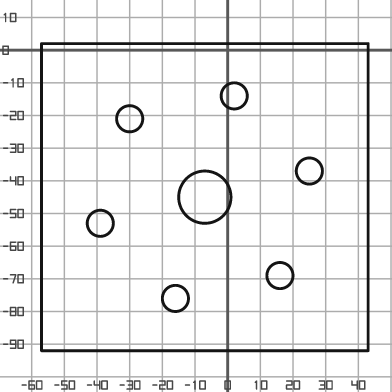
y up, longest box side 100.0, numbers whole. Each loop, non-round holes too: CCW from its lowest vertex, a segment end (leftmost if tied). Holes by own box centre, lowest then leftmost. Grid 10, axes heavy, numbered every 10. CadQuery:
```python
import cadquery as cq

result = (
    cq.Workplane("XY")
    .moveTo(-57.0, -92.0)
    .lineTo(43.0, -92.0)
    .lineTo(43.0, 2.0)
    .lineTo(-57.0, 2.0)
    .close()
    .moveTo(-16.0, -76.0)
    .circle(4.0)
    .moveTo(16.0, -69.0)
    .circle(4.0)
    .moveTo(-39.0, -53.0)
    .circle(4.0)
    .moveTo(-7.0, -45.0)
    .circle(8.0)
    .moveTo(25.0, -37.0)
    .circle(4.0)
    .moveTo(-30.0, -21.0)
    .circle(4.0)
    .moveTo(2.0, -14.0)
    .circle(4.0)
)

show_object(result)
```